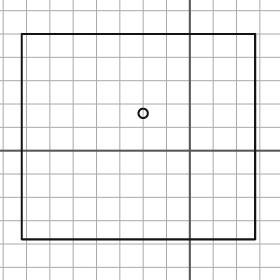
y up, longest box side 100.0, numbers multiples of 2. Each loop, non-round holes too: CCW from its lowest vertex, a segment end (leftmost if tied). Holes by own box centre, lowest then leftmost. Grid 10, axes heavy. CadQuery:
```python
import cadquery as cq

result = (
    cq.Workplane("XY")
    .moveTo(-72.0, -38.0)
    .lineTo(28.0, -38.0)
    .lineTo(28.0, 50.0)
    .lineTo(-72.0, 50.0)
    .close()
    .moveTo(-20.0, 16.0)
    .circle(2.0)
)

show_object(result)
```